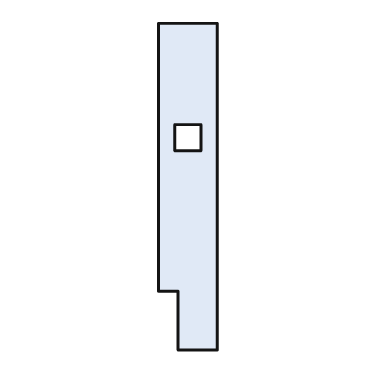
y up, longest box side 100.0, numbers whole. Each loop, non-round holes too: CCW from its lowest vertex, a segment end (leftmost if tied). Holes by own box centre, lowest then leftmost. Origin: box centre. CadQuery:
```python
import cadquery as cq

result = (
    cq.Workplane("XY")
    .moveTo(-3.0, -50.0)
    .lineTo(9.0, -50.0)
    .lineTo(9.0, 50.0)
    .lineTo(-9.0, 50.0)
    .lineTo(-9.0, -32.0)
    .lineTo(-3.0, -32.0)
    .close()
    .moveTo(-4.0, 11.0)
    .lineTo(4.0, 11.0)
    .lineTo(4.0, 19.0)
    .lineTo(-4.0, 19.0)
    .close()
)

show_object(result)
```